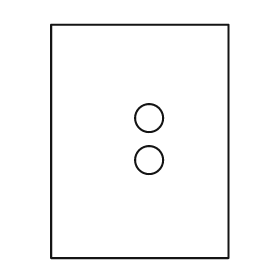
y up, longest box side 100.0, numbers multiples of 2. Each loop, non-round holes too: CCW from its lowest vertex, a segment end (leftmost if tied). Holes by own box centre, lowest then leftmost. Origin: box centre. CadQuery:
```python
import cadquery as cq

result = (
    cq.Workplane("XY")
    .moveTo(-38.0, -50.0)
    .lineTo(38.0, -50.0)
    .lineTo(38.0, 50.0)
    .lineTo(-38.0, 50.0)
    .close()
    .moveTo(4.0, -8.0)
    .circle(6.0)
    .moveTo(4.0, 10.0)
    .circle(6.0)
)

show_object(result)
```